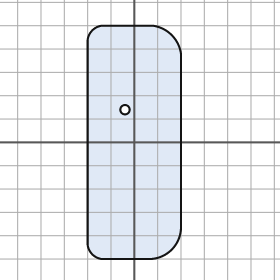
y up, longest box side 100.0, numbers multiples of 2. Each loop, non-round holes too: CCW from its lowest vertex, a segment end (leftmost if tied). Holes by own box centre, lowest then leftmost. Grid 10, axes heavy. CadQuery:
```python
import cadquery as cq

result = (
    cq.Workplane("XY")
    .moveTo(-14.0, -50.0)
    .lineTo(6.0, -50.0)
    .threePointArc((16.0, -46.0), (20.0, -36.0))
    .lineTo(20.0, 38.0)
    .threePointArc((16.0, 46.0), (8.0, 50.0))
    .lineTo(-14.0, 50.0)
    .threePointArc((-18.0, 48.0), (-20.0, 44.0))
    .lineTo(-20.0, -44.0)
    .threePointArc((-18.0, -48.0), (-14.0, -50.0))
    .close()
    .moveTo(-4.0, 14.0)
    .circle(2.0)
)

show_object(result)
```